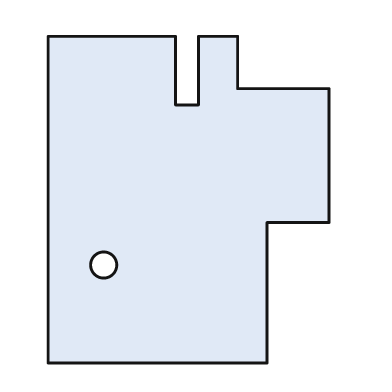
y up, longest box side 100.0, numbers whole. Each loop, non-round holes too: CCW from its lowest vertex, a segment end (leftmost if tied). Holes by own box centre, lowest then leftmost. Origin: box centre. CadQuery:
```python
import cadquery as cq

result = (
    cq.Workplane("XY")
    .moveTo(-43.0, -50.0)
    .lineTo(24.0, -50.0)
    .lineTo(24.0, -7.0)
    .lineTo(43.0, -7.0)
    .lineTo(43.0, 34.0)
    .lineTo(15.0, 34.0)
    .lineTo(15.0, 50.0)
    .lineTo(3.0, 50.0)
    .lineTo(3.0, 29.0)
    .lineTo(-4.0, 29.0)
    .lineTo(-4.0, 50.0)
    .lineTo(-43.0, 50.0)
    .close()
    .moveTo(-26.0, -20.0)
    .circle(4.0)
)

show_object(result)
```